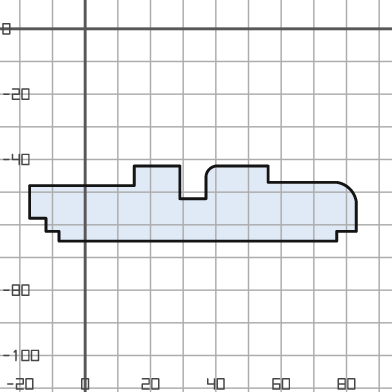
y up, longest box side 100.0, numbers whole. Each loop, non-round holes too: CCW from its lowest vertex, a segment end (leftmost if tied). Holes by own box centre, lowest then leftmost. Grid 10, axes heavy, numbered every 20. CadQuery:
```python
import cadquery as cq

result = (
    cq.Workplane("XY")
    .moveTo(-8.0, -65.0)
    .lineTo(77.0, -65.0)
    .lineTo(77.0, -62.0)
    .lineTo(83.0, -62.0)
    .lineTo(83.0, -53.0)
    .threePointArc((81.0, -49.0), (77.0, -47.0))
    .lineTo(56.0, -47.0)
    .lineTo(56.0, -42.0)
    .lineTo(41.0, -42.0)
    .threePointArc((38.0, -43.0), (37.0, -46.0))
    .lineTo(37.0, -52.0)
    .lineTo(29.0, -52.0)
    .lineTo(29.0, -42.0)
    .lineTo(15.0, -42.0)
    .lineTo(15.0, -48.0)
    .lineTo(-17.0, -48.0)
    .lineTo(-17.0, -58.0)
    .lineTo(-12.0, -58.0)
    .lineTo(-12.0, -62.0)
    .lineTo(-8.0, -62.0)
    .close()
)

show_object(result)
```